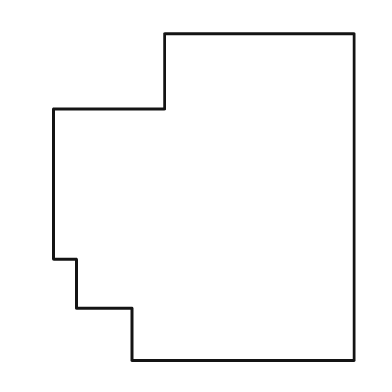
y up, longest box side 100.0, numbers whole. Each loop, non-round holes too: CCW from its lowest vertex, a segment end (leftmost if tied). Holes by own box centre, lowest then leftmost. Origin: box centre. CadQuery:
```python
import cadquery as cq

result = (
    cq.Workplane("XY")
    .moveTo(-22.0, -50.0)
    .lineTo(46.0, -50.0)
    .lineTo(46.0, 50.0)
    .lineTo(-12.0, 50.0)
    .lineTo(-12.0, 27.0)
    .lineTo(-46.0, 27.0)
    .lineTo(-46.0, -19.0)
    .lineTo(-39.0, -19.0)
    .lineTo(-39.0, -34.0)
    .lineTo(-22.0, -34.0)
    .close()
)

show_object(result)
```